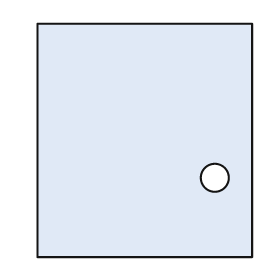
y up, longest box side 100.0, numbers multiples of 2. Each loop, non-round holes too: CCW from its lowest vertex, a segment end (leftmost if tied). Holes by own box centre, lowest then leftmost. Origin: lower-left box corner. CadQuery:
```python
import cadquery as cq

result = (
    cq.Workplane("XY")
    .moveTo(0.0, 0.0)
    .lineTo(92.0, 0.0)
    .lineTo(92.0, 100.0)
    .lineTo(0.0, 100.0)
    .close()
    .moveTo(76.0, 34.0)
    .circle(6.0)
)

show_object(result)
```